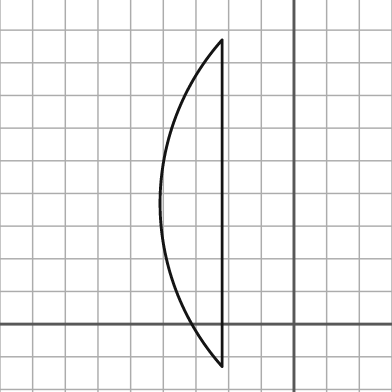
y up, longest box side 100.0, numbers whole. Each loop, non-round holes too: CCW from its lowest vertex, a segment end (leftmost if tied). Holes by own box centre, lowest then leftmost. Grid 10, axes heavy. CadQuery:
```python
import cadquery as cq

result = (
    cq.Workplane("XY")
    .moveTo(-22.0, -13.0)
    .lineTo(-22.0, 87.0)
    .threePointArc((-41.0, 37.0), (-22.0, -13.0))
    .close()
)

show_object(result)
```